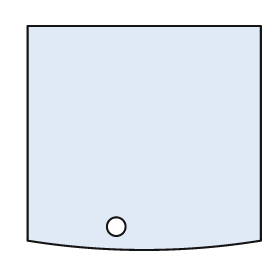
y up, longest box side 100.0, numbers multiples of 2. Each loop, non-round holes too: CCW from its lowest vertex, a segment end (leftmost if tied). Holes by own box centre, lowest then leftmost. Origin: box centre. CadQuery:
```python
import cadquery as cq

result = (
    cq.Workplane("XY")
    .moveTo(-50.0, -44.0)
    .threePointArc((0.0, -48.0), (50.0, -44.0))
    .lineTo(50.0, 48.0)
    .lineTo(-50.0, 48.0)
    .close()
    .moveTo(-12.0, -38.0)
    .circle(4.0)
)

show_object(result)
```